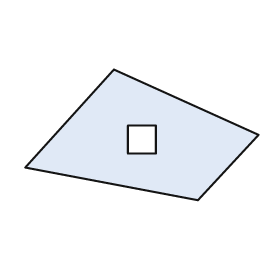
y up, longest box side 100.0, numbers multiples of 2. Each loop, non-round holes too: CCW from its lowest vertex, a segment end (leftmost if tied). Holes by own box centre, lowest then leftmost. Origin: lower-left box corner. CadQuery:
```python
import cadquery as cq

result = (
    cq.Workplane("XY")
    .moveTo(74.0, 0.0)
    .lineTo(100.0, 28.0)
    .lineTo(38.0, 56.0)
    .lineTo(0.0, 14.0)
    .close()
    .moveTo(44.0, 20.0)
    .lineTo(56.0, 20.0)
    .lineTo(56.0, 32.0)
    .lineTo(44.0, 32.0)
    .close()
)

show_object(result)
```